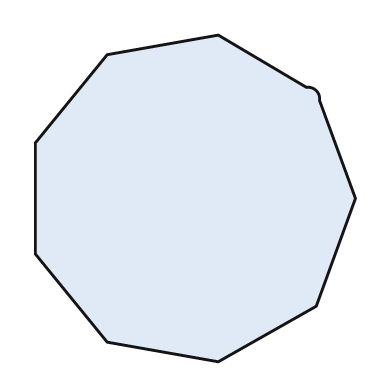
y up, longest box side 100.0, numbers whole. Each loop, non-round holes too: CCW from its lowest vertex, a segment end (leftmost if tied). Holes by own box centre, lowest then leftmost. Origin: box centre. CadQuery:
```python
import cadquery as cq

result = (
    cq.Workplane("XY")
    .moveTo(7.0, -50.0)
    .lineTo(37.0, -33.0)
    .lineTo(49.0, 0.0)
    .lineTo(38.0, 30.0)
    .threePointArc((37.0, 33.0), (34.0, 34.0))
    .lineTo(7.0, 50.0)
    .lineTo(-27.0, 44.0)
    .lineTo(-49.0, 17.0)
    .lineTo(-49.0, -17.0)
    .lineTo(-27.0, -44.0)
    .close()
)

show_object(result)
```